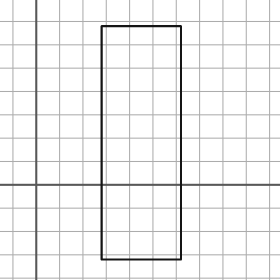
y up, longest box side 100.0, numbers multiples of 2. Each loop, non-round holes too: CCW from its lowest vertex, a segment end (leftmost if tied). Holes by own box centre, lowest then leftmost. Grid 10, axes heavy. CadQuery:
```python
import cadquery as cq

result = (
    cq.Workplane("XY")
    .moveTo(28.0, -32.0)
    .lineTo(62.0, -32.0)
    .lineTo(62.0, 68.0)
    .lineTo(28.0, 68.0)
    .close()
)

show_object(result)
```